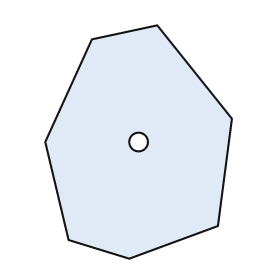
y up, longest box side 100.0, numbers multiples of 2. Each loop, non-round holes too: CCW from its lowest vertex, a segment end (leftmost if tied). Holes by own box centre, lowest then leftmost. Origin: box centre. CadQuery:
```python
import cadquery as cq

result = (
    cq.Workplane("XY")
    .moveTo(-4.0, -50.0)
    .lineTo(34.0, -36.0)
    .lineTo(40.0, 10.0)
    .lineTo(8.0, 50.0)
    .lineTo(-20.0, 44.0)
    .lineTo(-40.0, 0.0)
    .lineTo(-30.0, -42.0)
    .close()
    .moveTo(0.0, 0.0)
    .circle(4.0)
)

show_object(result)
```